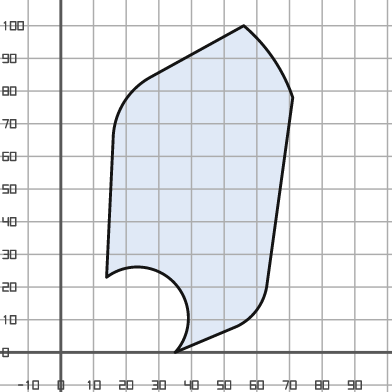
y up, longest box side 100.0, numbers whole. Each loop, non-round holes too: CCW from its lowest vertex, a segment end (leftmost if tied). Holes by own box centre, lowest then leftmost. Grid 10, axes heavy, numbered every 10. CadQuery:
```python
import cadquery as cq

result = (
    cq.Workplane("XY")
    .moveTo(35.0, 0.0)
    .lineTo(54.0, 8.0)
    .threePointArc((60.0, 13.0), (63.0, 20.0))
    .lineTo(71.0, 78.0)
    .threePointArc((65.0, 90.0), (56.0, 100.0))
    .lineTo(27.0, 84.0)
    .threePointArc((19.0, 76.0), (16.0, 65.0))
    .lineTo(14.0, 23.0)
    .threePointArc((35.0, 21.0), (35.0, 0.0))
    .close()
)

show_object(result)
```